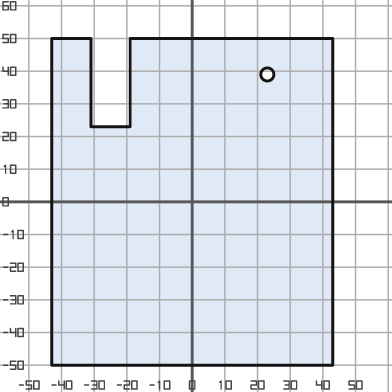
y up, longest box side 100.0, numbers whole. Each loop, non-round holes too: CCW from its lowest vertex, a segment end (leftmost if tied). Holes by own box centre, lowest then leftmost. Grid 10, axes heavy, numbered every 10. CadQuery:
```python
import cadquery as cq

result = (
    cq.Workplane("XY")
    .moveTo(-43.0, -50.0)
    .lineTo(43.0, -50.0)
    .lineTo(43.0, 50.0)
    .lineTo(-19.0, 50.0)
    .lineTo(-19.0, 23.0)
    .lineTo(-31.0, 23.0)
    .lineTo(-31.0, 50.0)
    .lineTo(-43.0, 50.0)
    .close()
    .moveTo(23.0, 39.0)
    .circle(2.0)
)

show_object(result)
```